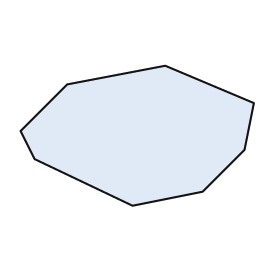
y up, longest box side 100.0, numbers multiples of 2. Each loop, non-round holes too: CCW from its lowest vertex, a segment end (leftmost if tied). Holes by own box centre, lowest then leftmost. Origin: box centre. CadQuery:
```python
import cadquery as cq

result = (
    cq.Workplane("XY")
    .moveTo(-2.0, -30.0)
    .lineTo(28.0, -24.0)
    .lineTo(46.0, -6.0)
    .lineTo(50.0, 14.0)
    .lineTo(12.0, 30.0)
    .lineTo(-30.0, 22.0)
    .lineTo(-50.0, 2.0)
    .lineTo(-44.0, -10.0)
    .close()
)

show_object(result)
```